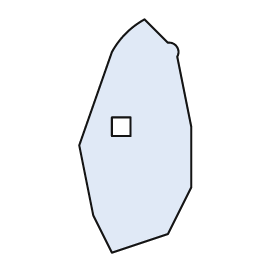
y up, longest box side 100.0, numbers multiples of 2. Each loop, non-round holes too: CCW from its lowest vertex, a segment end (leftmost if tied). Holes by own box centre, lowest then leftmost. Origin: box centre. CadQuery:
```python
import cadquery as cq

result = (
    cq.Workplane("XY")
    .moveTo(-10.0, -50.0)
    .lineTo(14.0, -42.0)
    .lineTo(24.0, -22.0)
    .lineTo(24.0, 4.0)
    .lineTo(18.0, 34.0)
    .threePointArc((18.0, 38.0), (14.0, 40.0))
    .lineTo(4.0, 50.0)
    .threePointArc((-4.0, 44.0), (-10.0, 36.0))
    .lineTo(-24.0, -4.0)
    .lineTo(-18.0, -34.0)
    .close()
    .moveTo(-10.0, 0.0)
    .lineTo(-2.0, 0.0)
    .lineTo(-2.0, 8.0)
    .lineTo(-10.0, 8.0)
    .close()
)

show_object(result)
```